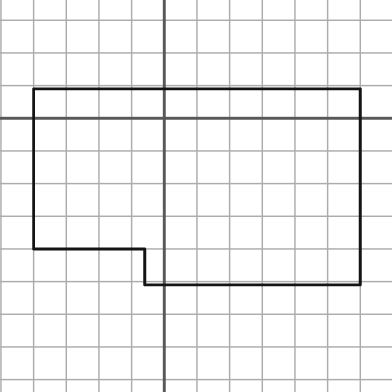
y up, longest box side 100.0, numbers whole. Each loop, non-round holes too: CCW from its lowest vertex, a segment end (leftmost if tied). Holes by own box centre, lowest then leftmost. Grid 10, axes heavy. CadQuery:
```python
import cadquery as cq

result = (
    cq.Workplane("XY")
    .moveTo(-6.0, -51.0)
    .lineTo(60.0, -51.0)
    .lineTo(60.0, 9.0)
    .lineTo(-40.0, 9.0)
    .lineTo(-40.0, -40.0)
    .lineTo(-6.0, -40.0)
    .close()
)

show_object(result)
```